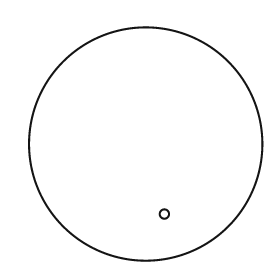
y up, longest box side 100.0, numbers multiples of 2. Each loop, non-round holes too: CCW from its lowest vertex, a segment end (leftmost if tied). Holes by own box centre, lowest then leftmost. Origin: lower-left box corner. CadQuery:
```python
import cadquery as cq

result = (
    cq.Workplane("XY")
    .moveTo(50.0, 50.0)
    .circle(50.0)
    .moveTo(58.0, 20.0)
    .circle(2.0)
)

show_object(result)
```